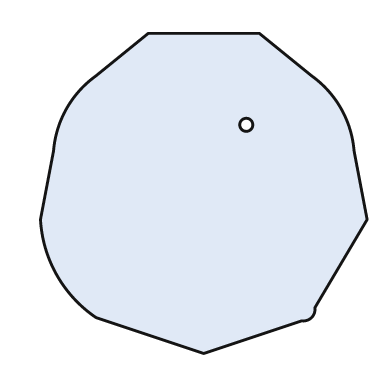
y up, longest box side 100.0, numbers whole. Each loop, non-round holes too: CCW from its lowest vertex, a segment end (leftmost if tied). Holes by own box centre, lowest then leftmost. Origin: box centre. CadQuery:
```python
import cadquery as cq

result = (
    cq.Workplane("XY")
    .moveTo(0.0, -49.0)
    .lineTo(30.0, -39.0)
    .threePointArc((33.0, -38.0), (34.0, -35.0))
    .lineTo(50.0, -8.0)
    .lineTo(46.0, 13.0)
    .threePointArc((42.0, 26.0), (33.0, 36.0))
    .lineTo(17.0, 49.0)
    .lineTo(-17.0, 49.0)
    .lineTo(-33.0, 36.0)
    .threePointArc((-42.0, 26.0), (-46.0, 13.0))
    .lineTo(-50.0, -8.0)
    .threePointArc((-45.0, -25.0), (-33.0, -38.0))
    .close()
    .moveTo(13.0, 21.0)
    .circle(2.0)
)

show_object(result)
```